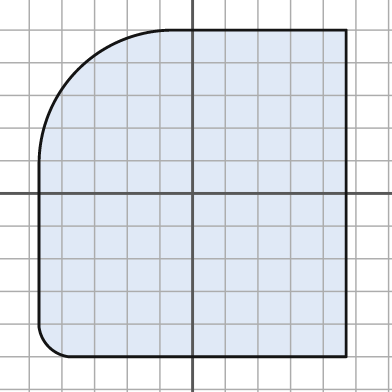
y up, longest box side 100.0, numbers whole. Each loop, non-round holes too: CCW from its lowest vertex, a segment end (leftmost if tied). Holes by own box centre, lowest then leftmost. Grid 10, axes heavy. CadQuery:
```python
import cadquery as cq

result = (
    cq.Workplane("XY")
    .moveTo(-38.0, -50.0)
    .lineTo(47.0, -50.0)
    .lineTo(47.0, 50.0)
    .lineTo(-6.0, 50.0)
    .threePointArc((-35.0, 38.0), (-47.0, 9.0))
    .lineTo(-47.0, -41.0)
    .threePointArc((-44.0, -47.0), (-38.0, -50.0))
    .close()
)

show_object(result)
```